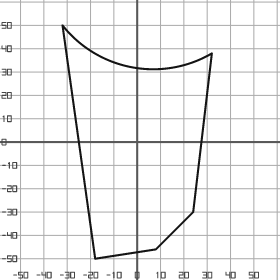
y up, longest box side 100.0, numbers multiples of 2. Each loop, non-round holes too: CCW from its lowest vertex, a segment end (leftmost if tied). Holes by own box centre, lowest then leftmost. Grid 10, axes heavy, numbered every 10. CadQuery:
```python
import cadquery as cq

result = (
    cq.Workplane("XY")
    .moveTo(-18.0, -50.0)
    .lineTo(8.0, -46.0)
    .lineTo(24.0, -30.0)
    .lineTo(32.0, 38.0)
    .threePointArc((-2.0, 32.0), (-32.0, 50.0))
    .close()
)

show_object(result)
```